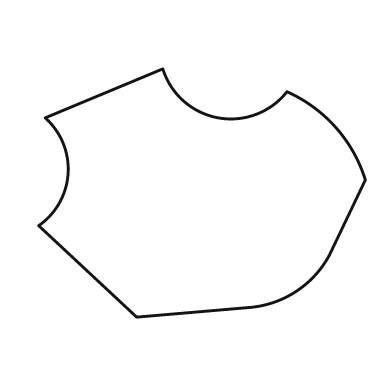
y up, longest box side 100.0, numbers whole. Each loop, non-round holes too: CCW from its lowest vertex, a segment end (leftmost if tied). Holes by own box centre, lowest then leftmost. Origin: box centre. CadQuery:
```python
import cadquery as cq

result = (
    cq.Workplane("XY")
    .moveTo(-20.0, -38.0)
    .lineTo(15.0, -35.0)
    .threePointArc((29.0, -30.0), (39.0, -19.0))
    .lineTo(50.0, 4.0)
    .threePointArc((41.0, 20.0), (26.0, 31.0))
    .threePointArc((5.0, 23.0), (-12.0, 38.0))
    .lineTo(-48.0, 23.0)
    .threePointArc((-41.0, 6.0), (-50.0, -10.0))
    .close()
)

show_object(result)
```